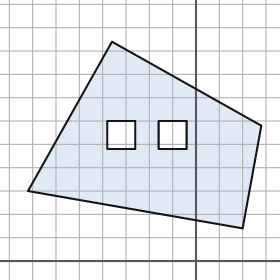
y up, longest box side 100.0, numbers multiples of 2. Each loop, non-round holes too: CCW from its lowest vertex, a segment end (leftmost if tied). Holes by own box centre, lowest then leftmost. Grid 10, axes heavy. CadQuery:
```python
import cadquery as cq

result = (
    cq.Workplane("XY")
    .moveTo(20.0, 14.0)
    .lineTo(28.0, 58.0)
    .lineTo(-36.0, 94.0)
    .lineTo(-72.0, 30.0)
    .close()
    .moveTo(-38.0, 48.0)
    .lineTo(-26.0, 48.0)
    .lineTo(-26.0, 60.0)
    .lineTo(-38.0, 60.0)
    .close()
    .moveTo(-16.0, 48.0)
    .lineTo(-4.0, 48.0)
    .lineTo(-4.0, 60.0)
    .lineTo(-16.0, 60.0)
    .close()
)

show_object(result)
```